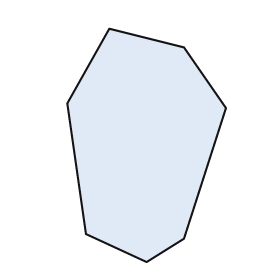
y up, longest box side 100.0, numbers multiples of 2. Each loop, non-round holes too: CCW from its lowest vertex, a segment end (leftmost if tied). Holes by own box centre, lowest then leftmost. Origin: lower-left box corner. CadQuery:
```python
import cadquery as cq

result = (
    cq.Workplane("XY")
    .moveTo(34.0, 0.0)
    .lineTo(50.0, 10.0)
    .lineTo(68.0, 66.0)
    .lineTo(50.0, 92.0)
    .lineTo(18.0, 100.0)
    .lineTo(0.0, 68.0)
    .lineTo(8.0, 12.0)
    .close()
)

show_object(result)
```